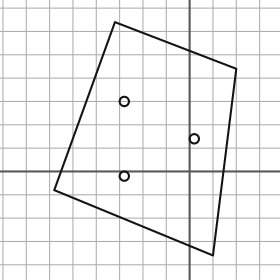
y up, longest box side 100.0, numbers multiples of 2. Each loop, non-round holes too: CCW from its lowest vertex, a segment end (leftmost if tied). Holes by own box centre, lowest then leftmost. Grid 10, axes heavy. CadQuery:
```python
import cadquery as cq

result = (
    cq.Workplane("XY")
    .moveTo(10.0, -36.0)
    .lineTo(20.0, 44.0)
    .lineTo(-32.0, 64.0)
    .lineTo(-58.0, -8.0)
    .close()
    .moveTo(-28.0, -2.0)
    .circle(2.0)
    .moveTo(2.0, 14.0)
    .circle(2.0)
    .moveTo(-28.0, 30.0)
    .circle(2.0)
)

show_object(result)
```